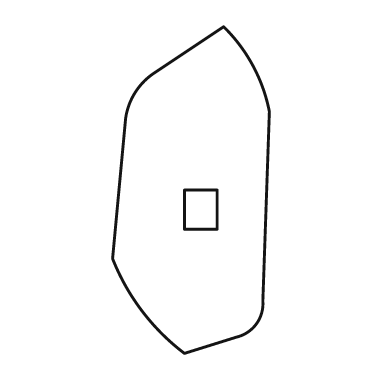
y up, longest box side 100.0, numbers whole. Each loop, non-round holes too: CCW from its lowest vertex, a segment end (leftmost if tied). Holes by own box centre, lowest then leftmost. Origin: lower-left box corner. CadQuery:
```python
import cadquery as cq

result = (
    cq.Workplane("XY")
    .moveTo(22.0, 0.0)
    .lineTo(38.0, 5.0)
    .threePointArc((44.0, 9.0), (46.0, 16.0))
    .lineTo(48.0, 74.0)
    .threePointArc((43.0, 88.0), (34.0, 100.0))
    .lineTo(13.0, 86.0)
    .threePointArc((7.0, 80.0), (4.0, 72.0))
    .lineTo(0.0, 29.0)
    .threePointArc((9.0, 13.0), (22.0, 0.0))
    .close()
    .moveTo(22.0, 38.0)
    .lineTo(32.0, 38.0)
    .lineTo(32.0, 50.0)
    .lineTo(22.0, 50.0)
    .close()
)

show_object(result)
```